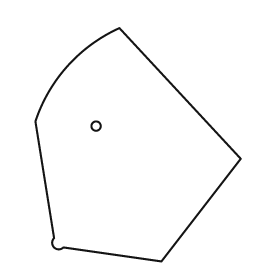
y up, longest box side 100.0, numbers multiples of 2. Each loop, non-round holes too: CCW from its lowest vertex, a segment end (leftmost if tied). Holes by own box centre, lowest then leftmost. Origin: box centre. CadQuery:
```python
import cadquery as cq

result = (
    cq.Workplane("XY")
    .moveTo(10.0, -50.0)
    .lineTo(44.0, -6.0)
    .lineTo(-8.0, 50.0)
    .threePointArc((-30.0, 34.0), (-44.0, 10.0))
    .lineTo(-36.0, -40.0)
    .threePointArc((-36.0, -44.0), (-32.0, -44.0))
    .close()
    .moveTo(-18.0, 8.0)
    .circle(2.0)
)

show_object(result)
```